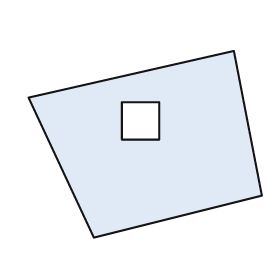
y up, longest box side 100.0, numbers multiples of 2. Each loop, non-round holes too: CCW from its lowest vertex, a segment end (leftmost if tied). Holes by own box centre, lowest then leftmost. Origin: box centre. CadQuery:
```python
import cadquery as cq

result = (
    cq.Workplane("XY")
    .moveTo(-22.0, -40.0)
    .lineTo(50.0, -22.0)
    .lineTo(38.0, 40.0)
    .lineTo(-50.0, 20.0)
    .close()
    .moveTo(-10.0, 2.0)
    .lineTo(6.0, 2.0)
    .lineTo(6.0, 18.0)
    .lineTo(-10.0, 18.0)
    .close()
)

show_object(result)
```